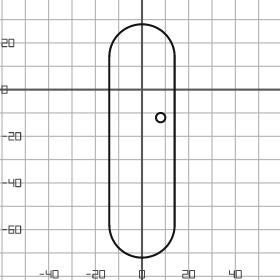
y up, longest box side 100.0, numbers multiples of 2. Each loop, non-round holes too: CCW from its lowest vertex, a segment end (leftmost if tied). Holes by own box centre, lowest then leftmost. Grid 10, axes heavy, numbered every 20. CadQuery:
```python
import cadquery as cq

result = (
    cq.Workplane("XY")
    .moveTo(-14.0, -58.0)
    .threePointArc((0.0, -72.0), (14.0, -58.0))
    .lineTo(14.0, 14.0)
    .threePointArc((0.0, 28.0), (-14.0, 14.0))
    .close()
    .moveTo(8.0, -12.0)
    .circle(2.0)
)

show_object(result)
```